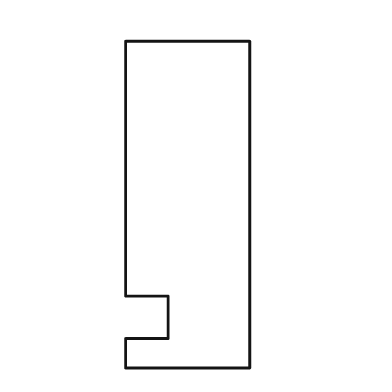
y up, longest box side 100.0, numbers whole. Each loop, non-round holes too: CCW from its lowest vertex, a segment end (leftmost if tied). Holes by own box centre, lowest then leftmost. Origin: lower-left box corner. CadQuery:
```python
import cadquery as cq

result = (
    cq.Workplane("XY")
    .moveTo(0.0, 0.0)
    .lineTo(38.0, 0.0)
    .lineTo(38.0, 100.0)
    .lineTo(0.0, 100.0)
    .lineTo(0.0, 22.0)
    .lineTo(13.0, 22.0)
    .lineTo(13.0, 9.0)
    .lineTo(0.0, 9.0)
    .close()
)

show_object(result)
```